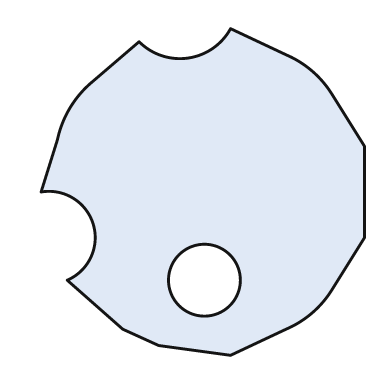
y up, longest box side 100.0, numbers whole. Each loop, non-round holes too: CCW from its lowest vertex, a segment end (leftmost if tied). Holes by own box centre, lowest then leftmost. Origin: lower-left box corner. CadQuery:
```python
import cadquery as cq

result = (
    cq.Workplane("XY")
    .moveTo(58.0, 0.0)
    .lineTo(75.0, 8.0)
    .threePointArc((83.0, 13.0), (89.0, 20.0))
    .lineTo(99.0, 36.0)
    .lineTo(99.0, 64.0)
    .lineTo(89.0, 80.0)
    .threePointArc((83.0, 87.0), (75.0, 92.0))
    .lineTo(58.0, 100.0)
    .threePointArc((45.0, 91.0), (30.0, 96.0))
    .lineTo(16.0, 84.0)
    .threePointArc((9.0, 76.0), (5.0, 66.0))
    .lineTo(0.0, 50.0)
    .threePointArc((16.0, 40.0), (8.0, 23.0))
    .lineTo(25.0, 8.0)
    .lineTo(36.0, 3.0)
    .close()
    .moveTo(50.0, 23.0)
    .circle(11.0)
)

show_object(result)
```